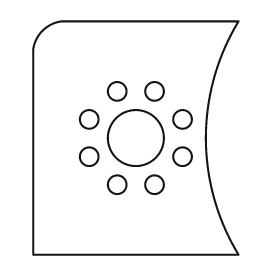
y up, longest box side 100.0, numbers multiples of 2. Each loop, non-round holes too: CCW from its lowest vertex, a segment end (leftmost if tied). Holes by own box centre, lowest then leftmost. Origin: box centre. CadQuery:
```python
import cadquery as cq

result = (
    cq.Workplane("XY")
    .moveTo(-44.0, -50.0)
    .lineTo(44.0, -50.0)
    .threePointArc((30.0, 0.0), (44.0, 50.0))
    .lineTo(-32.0, 50.0)
    .threePointArc((-40.0, 46.0), (-44.0, 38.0))
    .close()
    .moveTo(-8.0, -20.0)
    .circle(4.0)
    .moveTo(8.0, -20.0)
    .circle(4.0)
    .moveTo(-20.0, -8.0)
    .circle(4.0)
    .moveTo(20.0, -8.0)
    .circle(4.0)
    .moveTo(0.0, 0.0)
    .circle(12.0)
    .moveTo(-20.0, 8.0)
    .circle(4.0)
    .moveTo(20.0, 8.0)
    .circle(4.0)
    .moveTo(-8.0, 20.0)
    .circle(4.0)
    .moveTo(8.0, 20.0)
    .circle(4.0)
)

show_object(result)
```